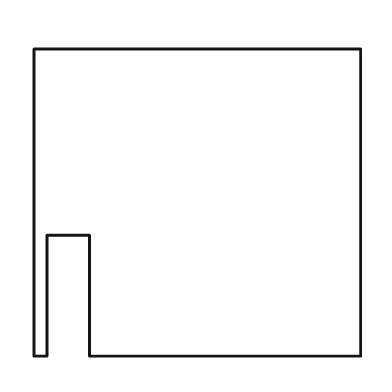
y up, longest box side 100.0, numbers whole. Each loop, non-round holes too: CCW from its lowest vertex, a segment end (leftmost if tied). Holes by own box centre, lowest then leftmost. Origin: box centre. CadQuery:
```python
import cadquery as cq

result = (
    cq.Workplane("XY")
    .moveTo(-50.0, -47.0)
    .lineTo(-46.0, -47.0)
    .lineTo(-46.0, -10.0)
    .lineTo(-33.0, -10.0)
    .lineTo(-33.0, -47.0)
    .lineTo(50.0, -47.0)
    .lineTo(50.0, 47.0)
    .lineTo(-50.0, 47.0)
    .close()
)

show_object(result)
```